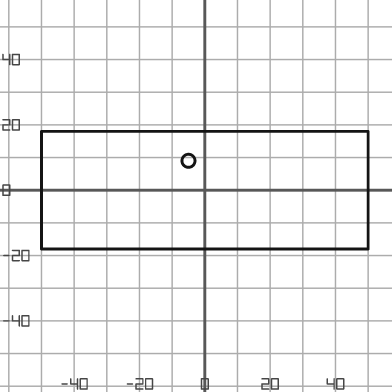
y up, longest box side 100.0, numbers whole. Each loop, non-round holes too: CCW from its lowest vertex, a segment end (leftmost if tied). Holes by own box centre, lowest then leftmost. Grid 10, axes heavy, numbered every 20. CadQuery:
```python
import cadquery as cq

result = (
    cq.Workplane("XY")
    .moveTo(-50.0, -18.0)
    .lineTo(50.0, -18.0)
    .lineTo(50.0, 18.0)
    .lineTo(-50.0, 18.0)
    .close()
    .moveTo(-5.0, 9.0)
    .circle(2.0)
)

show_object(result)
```